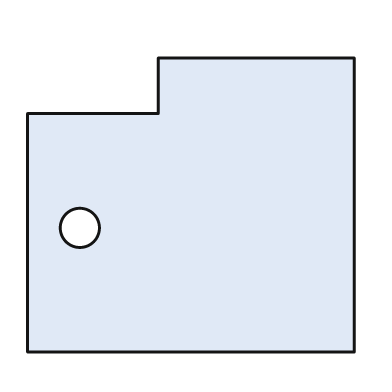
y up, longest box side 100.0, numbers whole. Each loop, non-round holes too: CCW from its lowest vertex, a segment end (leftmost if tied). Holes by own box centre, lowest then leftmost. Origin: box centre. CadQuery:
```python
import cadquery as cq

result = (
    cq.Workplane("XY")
    .moveTo(-50.0, -45.0)
    .lineTo(50.0, -45.0)
    .lineTo(50.0, 45.0)
    .lineTo(-10.0, 45.0)
    .lineTo(-10.0, 28.0)
    .lineTo(-50.0, 28.0)
    .close()
    .moveTo(-34.0, -7.0)
    .circle(6.0)
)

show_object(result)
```